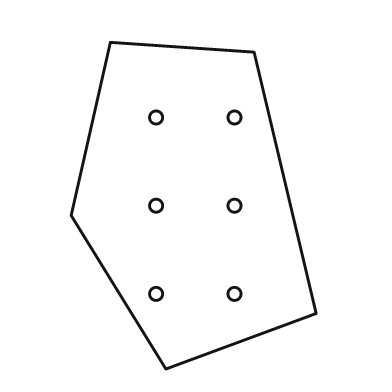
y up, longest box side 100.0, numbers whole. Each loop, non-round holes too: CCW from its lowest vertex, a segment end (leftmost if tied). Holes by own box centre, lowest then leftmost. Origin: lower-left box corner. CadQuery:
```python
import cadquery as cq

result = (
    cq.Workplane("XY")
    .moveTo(29.0, 0.0)
    .lineTo(75.0, 17.0)
    .lineTo(56.0, 97.0)
    .lineTo(12.0, 100.0)
    .lineTo(0.0, 47.0)
    .close()
    .moveTo(26.0, 23.0)
    .circle(2.0)
    .moveTo(50.0, 23.0)
    .circle(2.0)
    .moveTo(26.0, 50.0)
    .circle(2.0)
    .moveTo(50.0, 50.0)
    .circle(2.0)
    .moveTo(26.0, 77.0)
    .circle(2.0)
    .moveTo(50.0, 77.0)
    .circle(2.0)
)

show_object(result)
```